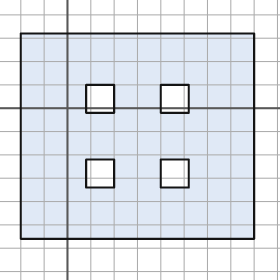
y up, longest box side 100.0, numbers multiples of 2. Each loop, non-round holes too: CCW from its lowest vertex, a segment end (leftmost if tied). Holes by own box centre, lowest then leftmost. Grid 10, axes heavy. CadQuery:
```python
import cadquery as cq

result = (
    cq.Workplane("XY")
    .moveTo(-20.0, -56.0)
    .lineTo(80.0, -56.0)
    .lineTo(80.0, 32.0)
    .lineTo(-20.0, 32.0)
    .close()
    .moveTo(8.0, -34.0)
    .lineTo(20.0, -34.0)
    .lineTo(20.0, -22.0)
    .lineTo(8.0, -22.0)
    .close()
    .moveTo(40.0, -34.0)
    .lineTo(52.0, -34.0)
    .lineTo(52.0, -22.0)
    .lineTo(40.0, -22.0)
    .close()
    .moveTo(8.0, -2.0)
    .lineTo(20.0, -2.0)
    .lineTo(20.0, 10.0)
    .lineTo(8.0, 10.0)
    .close()
    .moveTo(40.0, -2.0)
    .lineTo(52.0, -2.0)
    .lineTo(52.0, 10.0)
    .lineTo(40.0, 10.0)
    .close()
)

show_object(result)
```